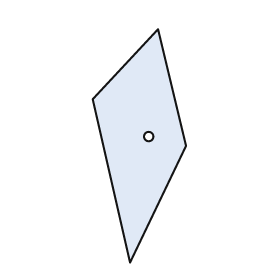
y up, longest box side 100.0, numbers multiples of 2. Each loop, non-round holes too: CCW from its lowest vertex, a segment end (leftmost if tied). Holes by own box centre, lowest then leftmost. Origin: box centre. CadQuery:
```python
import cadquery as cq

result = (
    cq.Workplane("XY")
    .moveTo(-4.0, -50.0)
    .lineTo(20.0, 0.0)
    .lineTo(8.0, 50.0)
    .lineTo(-20.0, 20.0)
    .close()
    .moveTo(4.0, 4.0)
    .circle(2.0)
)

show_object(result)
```